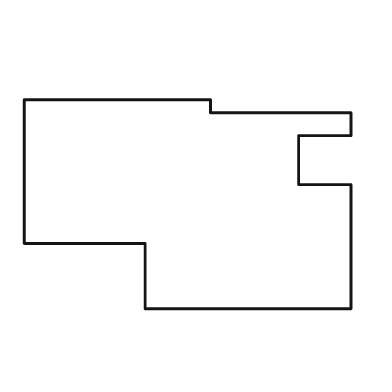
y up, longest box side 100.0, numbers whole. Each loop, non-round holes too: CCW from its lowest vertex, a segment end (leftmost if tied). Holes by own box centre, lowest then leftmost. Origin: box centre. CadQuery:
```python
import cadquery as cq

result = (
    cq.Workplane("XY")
    .moveTo(-13.0, -32.0)
    .lineTo(50.0, -32.0)
    .lineTo(50.0, 6.0)
    .lineTo(34.0, 6.0)
    .lineTo(34.0, 21.0)
    .lineTo(50.0, 21.0)
    .lineTo(50.0, 28.0)
    .lineTo(7.0, 28.0)
    .lineTo(7.0, 32.0)
    .lineTo(-50.0, 32.0)
    .lineTo(-50.0, -12.0)
    .lineTo(-13.0, -12.0)
    .close()
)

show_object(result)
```